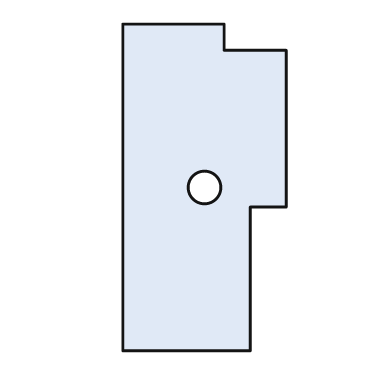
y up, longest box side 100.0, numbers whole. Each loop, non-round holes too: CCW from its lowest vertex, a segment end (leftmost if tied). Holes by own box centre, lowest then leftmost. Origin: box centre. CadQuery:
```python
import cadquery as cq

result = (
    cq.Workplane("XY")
    .moveTo(-25.0, -50.0)
    .lineTo(14.0, -50.0)
    .lineTo(14.0, -6.0)
    .lineTo(25.0, -6.0)
    .lineTo(25.0, 42.0)
    .lineTo(6.0, 42.0)
    .lineTo(6.0, 50.0)
    .lineTo(-25.0, 50.0)
    .close()
    .moveTo(0.0, 0.0)
    .circle(5.0)
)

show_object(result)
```